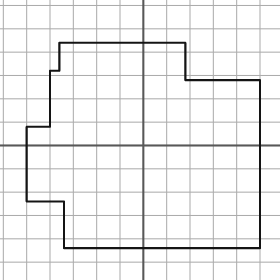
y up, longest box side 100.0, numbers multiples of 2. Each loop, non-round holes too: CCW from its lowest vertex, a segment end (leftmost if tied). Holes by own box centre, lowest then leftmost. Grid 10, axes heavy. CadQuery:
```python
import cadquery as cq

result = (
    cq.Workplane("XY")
    .moveTo(-34.0, -44.0)
    .lineTo(50.0, -44.0)
    .lineTo(50.0, 28.0)
    .lineTo(18.0, 28.0)
    .lineTo(18.0, 44.0)
    .lineTo(-36.0, 44.0)
    .lineTo(-36.0, 32.0)
    .lineTo(-40.0, 32.0)
    .lineTo(-40.0, 8.0)
    .lineTo(-50.0, 8.0)
    .lineTo(-50.0, -24.0)
    .lineTo(-34.0, -24.0)
    .close()
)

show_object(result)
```